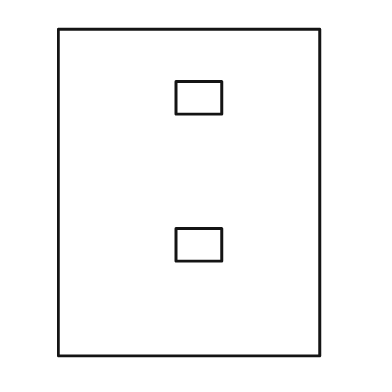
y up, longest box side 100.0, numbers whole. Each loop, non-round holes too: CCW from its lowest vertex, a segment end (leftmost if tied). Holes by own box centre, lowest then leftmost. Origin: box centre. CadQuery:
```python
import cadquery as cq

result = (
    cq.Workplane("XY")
    .moveTo(-40.0, -50.0)
    .lineTo(40.0, -50.0)
    .lineTo(40.0, 50.0)
    .lineTo(-40.0, 50.0)
    .close()
    .moveTo(-4.0, -21.0)
    .lineTo(10.0, -21.0)
    .lineTo(10.0, -11.0)
    .lineTo(-4.0, -11.0)
    .close()
    .moveTo(-4.0, 24.0)
    .lineTo(10.0, 24.0)
    .lineTo(10.0, 34.0)
    .lineTo(-4.0, 34.0)
    .close()
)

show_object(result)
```